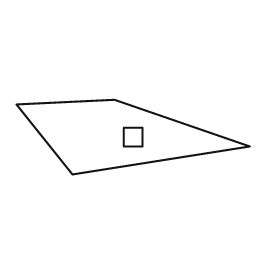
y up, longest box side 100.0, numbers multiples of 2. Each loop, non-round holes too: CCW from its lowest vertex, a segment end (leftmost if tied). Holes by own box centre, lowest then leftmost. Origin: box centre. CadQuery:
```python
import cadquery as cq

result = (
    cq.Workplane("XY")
    .moveTo(-26.0, -16.0)
    .lineTo(50.0, -4.0)
    .lineTo(-8.0, 16.0)
    .lineTo(-50.0, 14.0)
    .close()
    .moveTo(-4.0, -4.0)
    .lineTo(4.0, -4.0)
    .lineTo(4.0, 4.0)
    .lineTo(-4.0, 4.0)
    .close()
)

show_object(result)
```